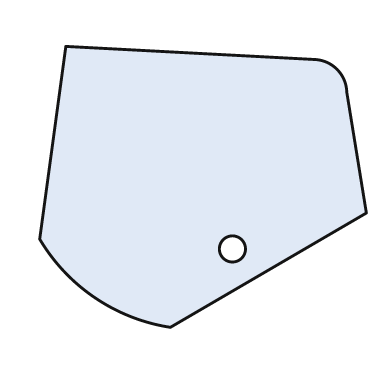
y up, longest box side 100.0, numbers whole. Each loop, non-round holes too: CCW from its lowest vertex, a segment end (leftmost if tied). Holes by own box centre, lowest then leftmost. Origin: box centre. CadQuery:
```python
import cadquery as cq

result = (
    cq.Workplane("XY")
    .moveTo(-10.0, -43.0)
    .lineTo(50.0, -8.0)
    .lineTo(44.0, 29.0)
    .threePointArc((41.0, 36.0), (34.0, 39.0))
    .lineTo(-42.0, 43.0)
    .lineTo(-50.0, -16.0)
    .threePointArc((-33.0, -34.0), (-10.0, -43.0))
    .close()
    .moveTo(9.0, -19.0)
    .circle(4.0)
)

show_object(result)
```